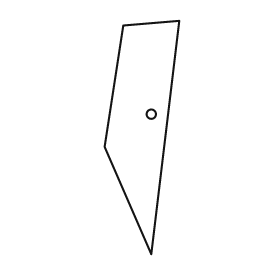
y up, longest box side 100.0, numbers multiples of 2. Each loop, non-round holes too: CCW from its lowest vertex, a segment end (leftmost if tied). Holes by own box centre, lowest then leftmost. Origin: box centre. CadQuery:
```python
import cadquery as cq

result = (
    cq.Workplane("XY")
    .moveTo(4.0, -50.0)
    .lineTo(16.0, 50.0)
    .lineTo(-8.0, 48.0)
    .lineTo(-16.0, -4.0)
    .close()
    .moveTo(4.0, 10.0)
    .circle(2.0)
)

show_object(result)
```